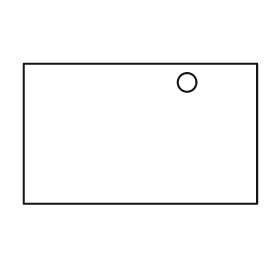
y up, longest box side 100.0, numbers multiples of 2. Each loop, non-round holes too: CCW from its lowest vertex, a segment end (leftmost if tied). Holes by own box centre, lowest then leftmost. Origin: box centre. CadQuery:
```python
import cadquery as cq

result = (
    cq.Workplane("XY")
    .moveTo(-50.0, -30.0)
    .lineTo(50.0, -30.0)
    .lineTo(50.0, 30.0)
    .lineTo(-50.0, 30.0)
    .close()
    .moveTo(20.0, 22.0)
    .circle(4.0)
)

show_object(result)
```